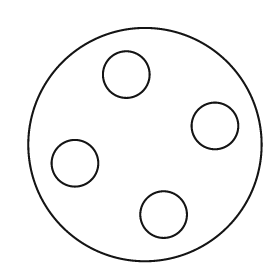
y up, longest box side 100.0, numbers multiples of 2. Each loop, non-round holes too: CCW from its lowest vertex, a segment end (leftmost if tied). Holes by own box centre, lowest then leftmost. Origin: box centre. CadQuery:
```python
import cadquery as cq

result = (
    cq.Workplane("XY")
    .moveTo(0.0, 0.0)
    .circle(50.0)
    .moveTo(8.0, -30.0)
    .circle(10.0)
    .moveTo(-30.0, -8.0)
    .circle(10.0)
    .moveTo(30.0, 8.0)
    .circle(10.0)
    .moveTo(-8.0, 30.0)
    .circle(10.0)
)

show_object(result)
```